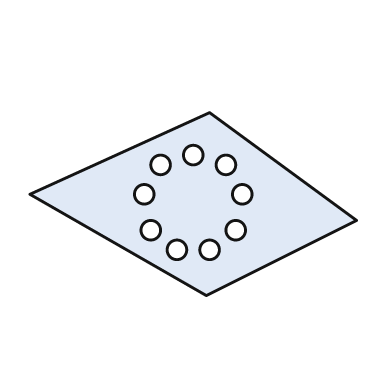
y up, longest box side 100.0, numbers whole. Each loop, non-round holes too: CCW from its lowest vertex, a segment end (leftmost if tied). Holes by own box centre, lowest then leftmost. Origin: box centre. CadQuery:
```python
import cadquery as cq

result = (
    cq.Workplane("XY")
    .moveTo(4.0, -28.0)
    .lineTo(50.0, -5.0)
    .lineTo(5.0, 28.0)
    .lineTo(-50.0, 3.0)
    .close()
    .moveTo(-5.0, -14.0)
    .circle(3.0)
    .moveTo(5.0, -14.0)
    .circle(3.0)
    .moveTo(-13.0, -8.0)
    .circle(3.0)
    .moveTo(13.0, -8.0)
    .circle(3.0)
    .moveTo(-15.0, 3.0)
    .circle(3.0)
    .moveTo(15.0, 3.0)
    .circle(3.0)
    .moveTo(-10.0, 12.0)
    .circle(3.0)
    .moveTo(10.0, 12.0)
    .circle(3.0)
    .moveTo(0.0, 15.0)
    .circle(3.0)
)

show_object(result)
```